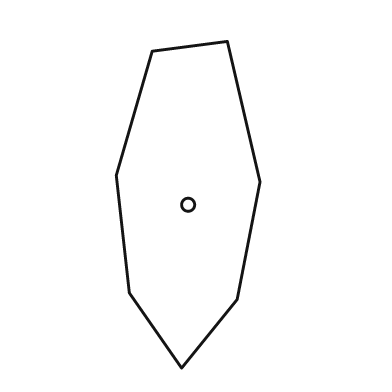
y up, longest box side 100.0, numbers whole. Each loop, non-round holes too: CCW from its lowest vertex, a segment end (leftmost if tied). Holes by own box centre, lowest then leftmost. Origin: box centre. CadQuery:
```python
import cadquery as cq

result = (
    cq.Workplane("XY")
    .moveTo(-2.0, -50.0)
    .lineTo(15.0, -29.0)
    .lineTo(22.0, 7.0)
    .lineTo(12.0, 50.0)
    .lineTo(-11.0, 47.0)
    .lineTo(-22.0, 9.0)
    .lineTo(-18.0, -27.0)
    .close()
    .moveTo(0.0, 0.0)
    .circle(2.0)
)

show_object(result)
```